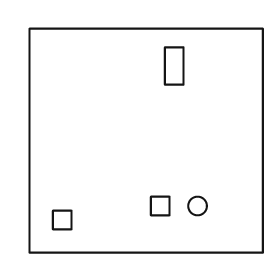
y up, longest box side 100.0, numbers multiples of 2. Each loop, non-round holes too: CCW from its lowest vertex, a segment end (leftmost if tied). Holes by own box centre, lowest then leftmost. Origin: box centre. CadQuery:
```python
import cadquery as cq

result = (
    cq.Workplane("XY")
    .moveTo(-50.0, -48.0)
    .lineTo(50.0, -48.0)
    .lineTo(50.0, 48.0)
    .lineTo(-50.0, 48.0)
    .close()
    .moveTo(-40.0, -38.0)
    .lineTo(-32.0, -38.0)
    .lineTo(-32.0, -30.0)
    .lineTo(-40.0, -30.0)
    .close()
    .moveTo(2.0, -32.0)
    .lineTo(10.0, -32.0)
    .lineTo(10.0, -24.0)
    .lineTo(2.0, -24.0)
    .close()
    .moveTo(22.0, -28.0)
    .circle(4.0)
    .moveTo(8.0, 24.0)
    .lineTo(16.0, 24.0)
    .lineTo(16.0, 40.0)
    .lineTo(8.0, 40.0)
    .close()
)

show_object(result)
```